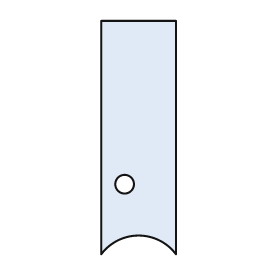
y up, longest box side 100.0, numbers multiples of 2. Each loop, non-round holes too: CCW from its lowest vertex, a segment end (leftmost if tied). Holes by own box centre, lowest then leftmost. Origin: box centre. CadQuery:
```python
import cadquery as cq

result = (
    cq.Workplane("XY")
    .moveTo(-16.0, -50.0)
    .threePointArc((0.0, -42.0), (16.0, -50.0))
    .lineTo(16.0, 50.0)
    .lineTo(-16.0, 50.0)
    .close()
    .moveTo(-6.0, -20.0)
    .circle(4.0)
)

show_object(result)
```